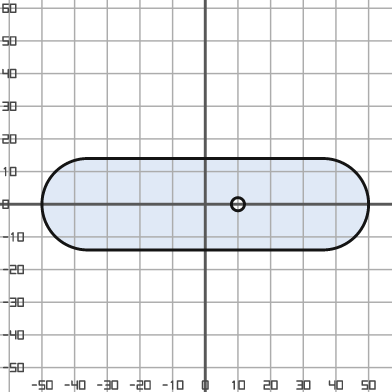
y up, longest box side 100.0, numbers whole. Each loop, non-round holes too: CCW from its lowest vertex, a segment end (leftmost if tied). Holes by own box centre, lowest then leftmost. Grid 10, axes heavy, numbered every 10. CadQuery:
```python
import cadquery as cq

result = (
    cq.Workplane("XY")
    .moveTo(-36.0, -14.0)
    .lineTo(36.0, -14.0)
    .threePointArc((50.0, 0.0), (36.0, 14.0))
    .lineTo(-36.0, 14.0)
    .threePointArc((-50.0, 0.0), (-36.0, -14.0))
    .close()
    .moveTo(10.0, 0.0)
    .circle(2.0)
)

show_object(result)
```